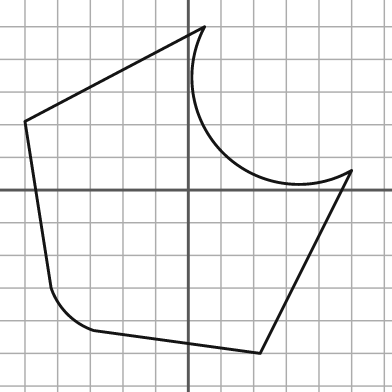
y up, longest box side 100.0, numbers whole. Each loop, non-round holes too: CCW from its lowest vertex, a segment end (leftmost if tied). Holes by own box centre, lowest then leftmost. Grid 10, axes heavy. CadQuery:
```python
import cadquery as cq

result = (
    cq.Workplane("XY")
    .moveTo(22.0, -50.0)
    .lineTo(50.0, 6.0)
    .threePointArc((11.0, 11.0), (5.0, 50.0))
    .lineTo(-50.0, 21.0)
    .lineTo(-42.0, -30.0)
    .threePointArc((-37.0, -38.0), (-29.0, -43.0))
    .close()
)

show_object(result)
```